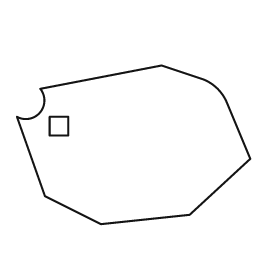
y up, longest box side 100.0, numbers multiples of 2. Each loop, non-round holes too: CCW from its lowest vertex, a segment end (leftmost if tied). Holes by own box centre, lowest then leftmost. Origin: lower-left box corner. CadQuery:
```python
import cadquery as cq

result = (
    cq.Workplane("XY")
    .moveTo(36.0, 0.0)
    .lineTo(74.0, 4.0)
    .lineTo(100.0, 28.0)
    .lineTo(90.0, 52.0)
    .threePointArc((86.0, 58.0), (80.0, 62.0))
    .lineTo(62.0, 68.0)
    .lineTo(10.0, 58.0)
    .threePointArc((10.0, 48.0), (0.0, 46.0))
    .lineTo(12.0, 12.0)
    .close()
    .moveTo(14.0, 38.0)
    .lineTo(22.0, 38.0)
    .lineTo(22.0, 46.0)
    .lineTo(14.0, 46.0)
    .close()
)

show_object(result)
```